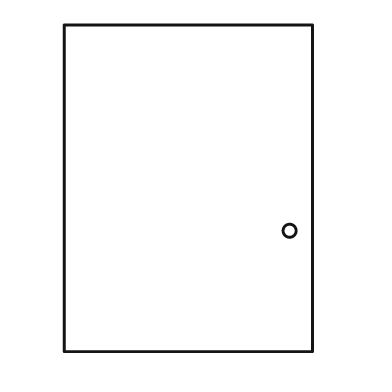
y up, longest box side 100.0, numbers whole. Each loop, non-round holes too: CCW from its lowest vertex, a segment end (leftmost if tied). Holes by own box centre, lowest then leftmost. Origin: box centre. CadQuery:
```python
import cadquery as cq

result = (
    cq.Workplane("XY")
    .moveTo(-38.0, -50.0)
    .lineTo(38.0, -50.0)
    .lineTo(38.0, 50.0)
    .lineTo(-38.0, 50.0)
    .close()
    .moveTo(31.0, -13.0)
    .circle(2.0)
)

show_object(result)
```